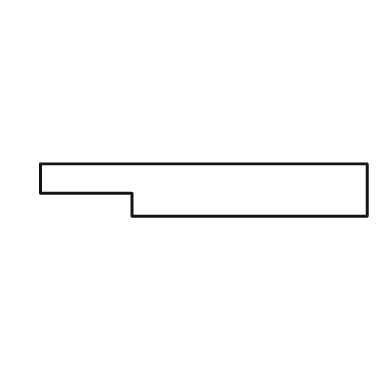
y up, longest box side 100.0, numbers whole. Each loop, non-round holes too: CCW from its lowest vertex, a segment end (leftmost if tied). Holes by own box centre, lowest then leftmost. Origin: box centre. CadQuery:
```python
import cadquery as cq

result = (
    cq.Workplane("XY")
    .moveTo(-22.0, -8.0)
    .lineTo(50.0, -8.0)
    .lineTo(50.0, 8.0)
    .lineTo(-50.0, 8.0)
    .lineTo(-50.0, -1.0)
    .lineTo(-22.0, -1.0)
    .close()
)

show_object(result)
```